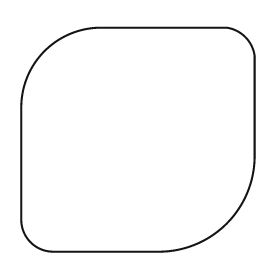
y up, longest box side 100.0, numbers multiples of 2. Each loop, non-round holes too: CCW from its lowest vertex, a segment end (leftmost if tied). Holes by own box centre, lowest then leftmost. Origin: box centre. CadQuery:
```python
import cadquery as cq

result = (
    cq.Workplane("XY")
    .moveTo(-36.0, -48.0)
    .lineTo(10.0, -48.0)
    .threePointArc((38.0, -36.0), (50.0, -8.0))
    .lineTo(50.0, 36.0)
    .threePointArc((46.0, 44.0), (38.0, 48.0))
    .lineTo(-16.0, 48.0)
    .threePointArc((-40.0, 38.0), (-50.0, 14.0))
    .lineTo(-50.0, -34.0)
    .threePointArc((-46.0, -44.0), (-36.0, -48.0))
    .close()
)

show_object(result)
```